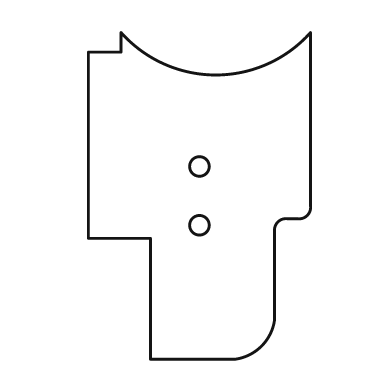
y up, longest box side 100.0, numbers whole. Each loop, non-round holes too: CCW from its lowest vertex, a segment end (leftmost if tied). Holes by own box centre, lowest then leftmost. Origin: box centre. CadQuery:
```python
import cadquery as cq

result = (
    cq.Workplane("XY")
    .moveTo(-15.0, -50.0)
    .lineTo(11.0, -50.0)
    .threePointArc((19.0, -46.0), (23.0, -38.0))
    .lineTo(23.0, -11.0)
    .threePointArc((24.0, -8.0), (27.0, -7.0))
    .lineTo(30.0, -7.0)
    .threePointArc((33.0, -6.0), (34.0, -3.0))
    .lineTo(34.0, 50.0)
    .threePointArc((5.0, 37.0), (-24.0, 50.0))
    .lineTo(-24.0, 44.0)
    .lineTo(-34.0, 44.0)
    .lineTo(-34.0, -13.0)
    .lineTo(-15.0, -13.0)
    .close()
    .moveTo(0.0, -9.0)
    .circle(3.0)
    .moveTo(0.0, 9.0)
    .circle(3.0)
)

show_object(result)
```